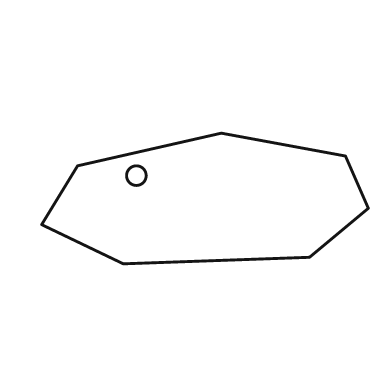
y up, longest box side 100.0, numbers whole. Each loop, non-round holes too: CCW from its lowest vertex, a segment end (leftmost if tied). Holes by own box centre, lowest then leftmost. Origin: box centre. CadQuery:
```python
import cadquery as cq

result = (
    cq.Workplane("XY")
    .moveTo(-25.0, -20.0)
    .lineTo(32.0, -18.0)
    .lineTo(50.0, -3.0)
    .lineTo(43.0, 13.0)
    .lineTo(5.0, 20.0)
    .lineTo(-39.0, 10.0)
    .lineTo(-50.0, -8.0)
    .close()
    .moveTo(-21.0, 7.0)
    .circle(3.0)
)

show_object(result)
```